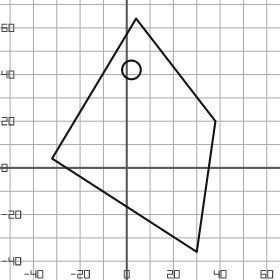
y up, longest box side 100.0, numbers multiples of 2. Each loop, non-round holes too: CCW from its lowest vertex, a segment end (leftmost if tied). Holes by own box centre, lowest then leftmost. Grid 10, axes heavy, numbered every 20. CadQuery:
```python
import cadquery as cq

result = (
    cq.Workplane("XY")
    .moveTo(30.0, -36.0)
    .lineTo(38.0, 20.0)
    .lineTo(4.0, 64.0)
    .lineTo(-32.0, 4.0)
    .close()
    .moveTo(2.0, 42.0)
    .circle(4.0)
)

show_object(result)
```